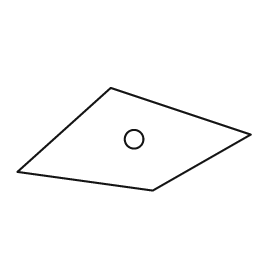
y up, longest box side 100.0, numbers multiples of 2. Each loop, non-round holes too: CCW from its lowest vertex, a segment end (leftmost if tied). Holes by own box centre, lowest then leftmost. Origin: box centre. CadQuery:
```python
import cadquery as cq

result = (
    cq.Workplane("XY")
    .moveTo(8.0, -22.0)
    .lineTo(50.0, 2.0)
    .lineTo(-10.0, 22.0)
    .lineTo(-50.0, -14.0)
    .close()
    .moveTo(0.0, 0.0)
    .circle(4.0)
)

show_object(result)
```